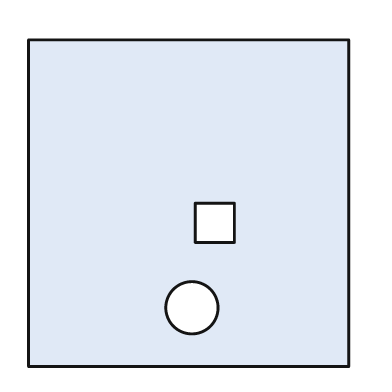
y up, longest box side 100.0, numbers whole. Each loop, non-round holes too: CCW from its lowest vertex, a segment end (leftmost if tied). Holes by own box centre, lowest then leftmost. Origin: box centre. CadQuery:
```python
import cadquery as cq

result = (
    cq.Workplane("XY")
    .moveTo(-49.0, -50.0)
    .lineTo(49.0, -50.0)
    .lineTo(49.0, 50.0)
    .lineTo(-49.0, 50.0)
    .close()
    .moveTo(1.0, -32.0)
    .circle(8.0)
    .moveTo(2.0, -12.0)
    .lineTo(14.0, -12.0)
    .lineTo(14.0, 0.0)
    .lineTo(2.0, 0.0)
    .close()
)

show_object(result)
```